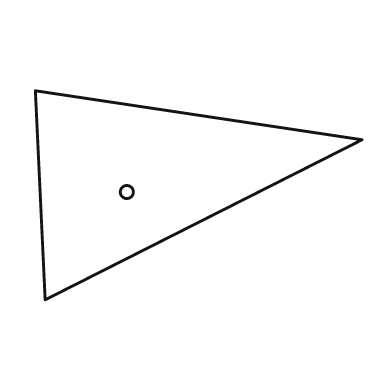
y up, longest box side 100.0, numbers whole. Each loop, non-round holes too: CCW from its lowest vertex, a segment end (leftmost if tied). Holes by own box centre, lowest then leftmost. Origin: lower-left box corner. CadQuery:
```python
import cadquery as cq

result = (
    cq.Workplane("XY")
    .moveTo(3.0, 0.0)
    .lineTo(100.0, 49.0)
    .lineTo(0.0, 64.0)
    .close()
    .moveTo(28.0, 33.0)
    .circle(2.0)
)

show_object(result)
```